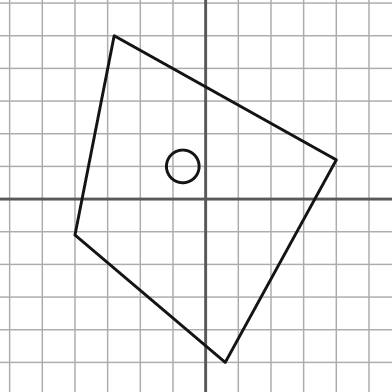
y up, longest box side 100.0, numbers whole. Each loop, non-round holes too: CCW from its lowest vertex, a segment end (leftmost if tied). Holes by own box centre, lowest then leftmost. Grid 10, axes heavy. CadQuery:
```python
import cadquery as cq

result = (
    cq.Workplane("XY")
    .moveTo(6.0, -50.0)
    .lineTo(40.0, 12.0)
    .lineTo(-28.0, 50.0)
    .lineTo(-40.0, -11.0)
    .close()
    .moveTo(-7.0, 10.0)
    .circle(5.0)
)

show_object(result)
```